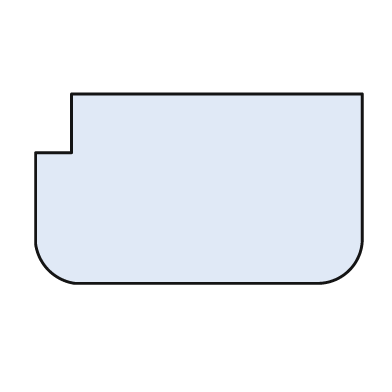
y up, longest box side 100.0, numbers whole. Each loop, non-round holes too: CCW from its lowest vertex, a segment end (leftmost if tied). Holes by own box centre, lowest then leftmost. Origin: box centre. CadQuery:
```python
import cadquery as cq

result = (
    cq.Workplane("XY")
    .moveTo(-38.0, -29.0)
    .lineTo(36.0, -29.0)
    .threePointArc((46.0, -25.0), (50.0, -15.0))
    .lineTo(50.0, 29.0)
    .lineTo(-39.0, 29.0)
    .lineTo(-39.0, 11.0)
    .lineTo(-50.0, 11.0)
    .lineTo(-50.0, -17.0)
    .threePointArc((-46.0, -25.0), (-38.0, -29.0))
    .close()
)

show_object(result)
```